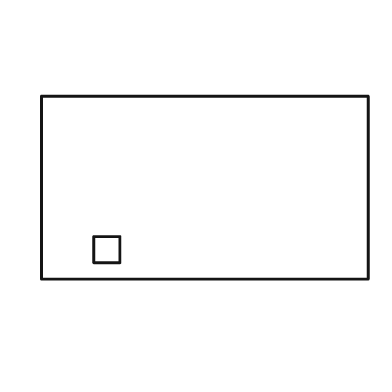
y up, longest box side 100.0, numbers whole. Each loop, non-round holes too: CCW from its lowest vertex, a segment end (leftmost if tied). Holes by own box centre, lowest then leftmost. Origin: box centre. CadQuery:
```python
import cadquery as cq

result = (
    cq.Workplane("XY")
    .moveTo(-50.0, -28.0)
    .lineTo(50.0, -28.0)
    .lineTo(50.0, 28.0)
    .lineTo(-50.0, 28.0)
    .close()
    .moveTo(-34.0, -23.0)
    .lineTo(-26.0, -23.0)
    .lineTo(-26.0, -15.0)
    .lineTo(-34.0, -15.0)
    .close()
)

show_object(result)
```